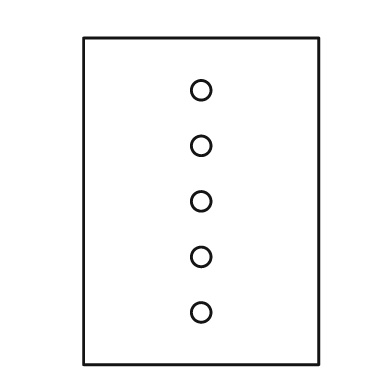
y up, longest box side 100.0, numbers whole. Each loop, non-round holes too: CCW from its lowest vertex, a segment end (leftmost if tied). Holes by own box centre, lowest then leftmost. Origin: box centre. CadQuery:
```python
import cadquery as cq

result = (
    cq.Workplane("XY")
    .moveTo(-36.0, -50.0)
    .lineTo(36.0, -50.0)
    .lineTo(36.0, 50.0)
    .lineTo(-36.0, 50.0)
    .close()
    .moveTo(0.0, -34.0)
    .circle(3.0)
    .moveTo(0.0, -17.0)
    .circle(3.0)
    .moveTo(0.0, 0.0)
    .circle(3.0)
    .moveTo(0.0, 17.0)
    .circle(3.0)
    .moveTo(0.0, 34.0)
    .circle(3.0)
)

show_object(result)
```